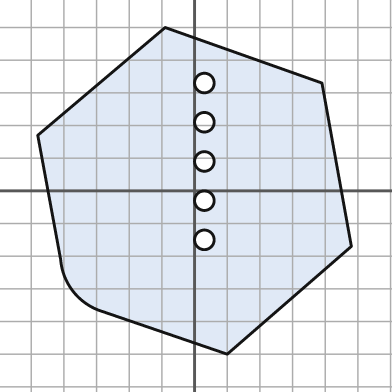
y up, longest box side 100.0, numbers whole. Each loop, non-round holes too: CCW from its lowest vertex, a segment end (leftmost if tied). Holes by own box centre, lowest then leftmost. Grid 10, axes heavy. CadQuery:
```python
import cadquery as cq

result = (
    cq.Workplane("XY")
    .moveTo(10.0, -50.0)
    .lineTo(48.0, -17.0)
    .lineTo(39.0, 33.0)
    .lineTo(-9.0, 50.0)
    .lineTo(-48.0, 17.0)
    .lineTo(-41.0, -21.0)
    .threePointArc((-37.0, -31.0), (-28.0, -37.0))
    .close()
    .moveTo(3.0, -15.0)
    .circle(3.0)
    .moveTo(3.0, -3.0)
    .circle(3.0)
    .moveTo(3.0, 9.0)
    .circle(3.0)
    .moveTo(3.0, 21.0)
    .circle(3.0)
    .moveTo(3.0, 33.0)
    .circle(3.0)
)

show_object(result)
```